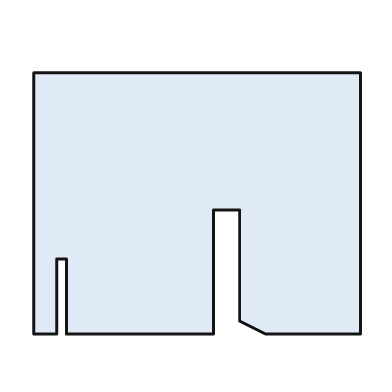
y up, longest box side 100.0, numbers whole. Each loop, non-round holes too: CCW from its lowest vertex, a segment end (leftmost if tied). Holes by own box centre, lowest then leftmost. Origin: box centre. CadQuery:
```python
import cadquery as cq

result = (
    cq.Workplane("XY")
    .moveTo(-50.0, -40.0)
    .lineTo(-43.0, -40.0)
    .lineTo(-43.0, -17.0)
    .lineTo(-40.0, -17.0)
    .lineTo(-40.0, -40.0)
    .lineTo(5.0, -40.0)
    .lineTo(5.0, -2.0)
    .lineTo(13.0, -2.0)
    .lineTo(13.0, -36.0)
    .lineTo(21.0, -40.0)
    .lineTo(50.0, -40.0)
    .lineTo(50.0, 40.0)
    .lineTo(-50.0, 40.0)
    .close()
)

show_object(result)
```